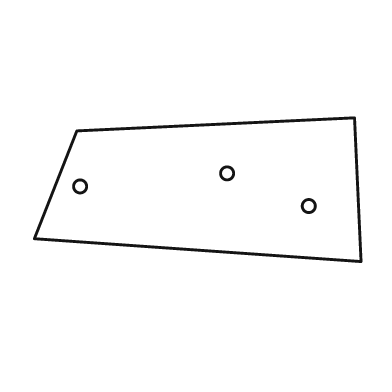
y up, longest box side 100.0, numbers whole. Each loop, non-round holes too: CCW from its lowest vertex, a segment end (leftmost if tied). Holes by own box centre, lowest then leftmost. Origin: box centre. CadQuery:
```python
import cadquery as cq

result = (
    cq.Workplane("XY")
    .moveTo(50.0, -22.0)
    .lineTo(48.0, 22.0)
    .lineTo(-37.0, 18.0)
    .lineTo(-50.0, -15.0)
    .close()
    .moveTo(34.0, -5.0)
    .circle(2.0)
    .moveTo(-36.0, 1.0)
    .circle(2.0)
    .moveTo(9.0, 5.0)
    .circle(2.0)
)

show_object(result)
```